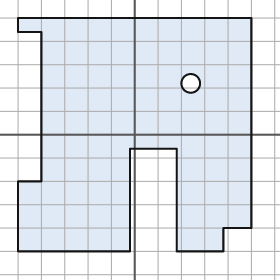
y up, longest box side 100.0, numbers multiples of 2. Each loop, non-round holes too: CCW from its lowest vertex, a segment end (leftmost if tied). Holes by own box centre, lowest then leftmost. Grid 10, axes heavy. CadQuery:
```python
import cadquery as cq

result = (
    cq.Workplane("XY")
    .moveTo(-50.0, -50.0)
    .lineTo(-2.0, -50.0)
    .lineTo(-2.0, -6.0)
    .lineTo(18.0, -6.0)
    .lineTo(18.0, -50.0)
    .lineTo(38.0, -50.0)
    .lineTo(38.0, -40.0)
    .lineTo(50.0, -40.0)
    .lineTo(50.0, 50.0)
    .lineTo(-50.0, 50.0)
    .lineTo(-50.0, 44.0)
    .lineTo(-40.0, 44.0)
    .lineTo(-40.0, -20.0)
    .lineTo(-50.0, -20.0)
    .close()
    .moveTo(24.0, 22.0)
    .circle(4.0)
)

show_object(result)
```